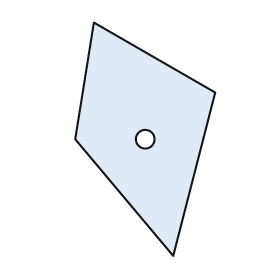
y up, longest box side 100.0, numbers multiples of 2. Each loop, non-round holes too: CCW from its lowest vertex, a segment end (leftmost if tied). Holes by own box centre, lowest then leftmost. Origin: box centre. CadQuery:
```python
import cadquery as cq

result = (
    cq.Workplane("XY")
    .moveTo(12.0, -50.0)
    .lineTo(30.0, 20.0)
    .lineTo(-22.0, 50.0)
    .lineTo(-30.0, 0.0)
    .close()
    .moveTo(0.0, 0.0)
    .circle(4.0)
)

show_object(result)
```